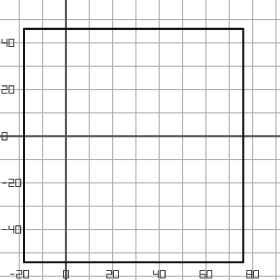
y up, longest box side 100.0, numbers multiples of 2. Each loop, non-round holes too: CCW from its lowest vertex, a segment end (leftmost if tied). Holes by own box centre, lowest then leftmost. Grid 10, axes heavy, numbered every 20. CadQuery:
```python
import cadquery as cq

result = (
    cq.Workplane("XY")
    .moveTo(-18.0, -54.0)
    .lineTo(76.0, -54.0)
    .lineTo(76.0, 46.0)
    .lineTo(-18.0, 46.0)
    .close()
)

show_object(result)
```